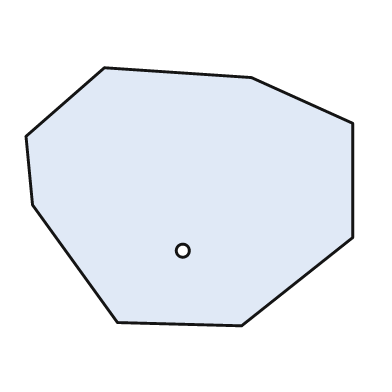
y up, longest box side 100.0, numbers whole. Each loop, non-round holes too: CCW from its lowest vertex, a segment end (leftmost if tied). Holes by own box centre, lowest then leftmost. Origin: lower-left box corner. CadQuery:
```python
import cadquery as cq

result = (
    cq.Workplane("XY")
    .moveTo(66.0, 0.0)
    .lineTo(100.0, 27.0)
    .lineTo(100.0, 62.0)
    .lineTo(69.0, 76.0)
    .lineTo(24.0, 79.0)
    .lineTo(0.0, 58.0)
    .lineTo(2.0, 37.0)
    .lineTo(28.0, 1.0)
    .close()
    .moveTo(48.0, 23.0)
    .circle(2.0)
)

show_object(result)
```